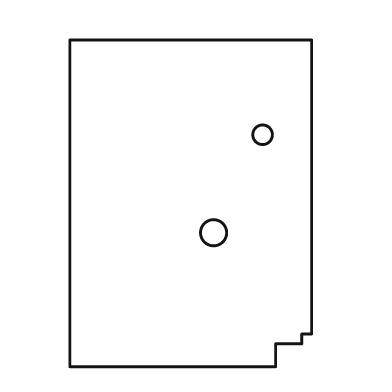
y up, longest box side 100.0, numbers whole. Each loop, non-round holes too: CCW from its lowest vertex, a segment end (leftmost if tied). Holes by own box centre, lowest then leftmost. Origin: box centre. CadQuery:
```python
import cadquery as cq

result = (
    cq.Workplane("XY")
    .moveTo(-37.0, -50.0)
    .lineTo(26.0, -50.0)
    .lineTo(26.0, -43.0)
    .lineTo(34.0, -43.0)
    .lineTo(34.0, -40.0)
    .lineTo(37.0, -40.0)
    .lineTo(37.0, 50.0)
    .lineTo(-37.0, 50.0)
    .close()
    .moveTo(7.0, -9.0)
    .circle(4.0)
    .moveTo(22.0, 21.0)
    .circle(3.0)
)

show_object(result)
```